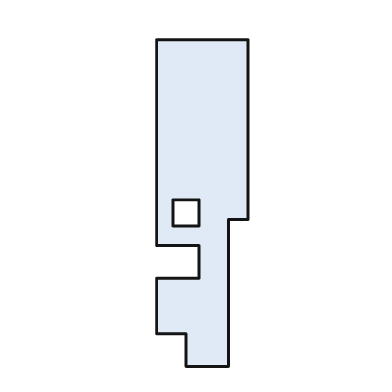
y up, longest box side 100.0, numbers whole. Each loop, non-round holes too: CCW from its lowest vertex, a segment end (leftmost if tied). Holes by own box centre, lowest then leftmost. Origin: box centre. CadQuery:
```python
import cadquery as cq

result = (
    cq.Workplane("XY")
    .moveTo(-5.0, -50.0)
    .lineTo(8.0, -50.0)
    .lineTo(8.0, -5.0)
    .lineTo(14.0, -5.0)
    .lineTo(14.0, 50.0)
    .lineTo(-14.0, 50.0)
    .lineTo(-14.0, -13.0)
    .lineTo(-1.0, -13.0)
    .lineTo(-1.0, -23.0)
    .lineTo(-14.0, -23.0)
    .lineTo(-14.0, -40.0)
    .lineTo(-5.0, -40.0)
    .close()
    .moveTo(-9.0, -7.0)
    .lineTo(-1.0, -7.0)
    .lineTo(-1.0, 1.0)
    .lineTo(-9.0, 1.0)
    .close()
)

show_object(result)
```